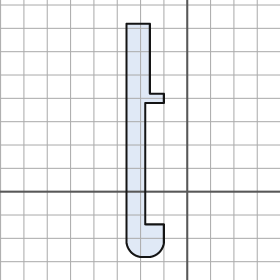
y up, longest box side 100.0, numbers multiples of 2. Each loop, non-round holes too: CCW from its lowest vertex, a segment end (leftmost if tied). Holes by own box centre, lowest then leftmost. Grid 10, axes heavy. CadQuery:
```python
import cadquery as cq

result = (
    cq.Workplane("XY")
    .moveTo(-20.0, -28.0)
    .lineTo(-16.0, -28.0)
    .threePointArc((-12.0, -26.0), (-10.0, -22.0))
    .lineTo(-10.0, -14.0)
    .lineTo(-18.0, -14.0)
    .lineTo(-18.0, 38.0)
    .lineTo(-10.0, 38.0)
    .lineTo(-10.0, 42.0)
    .lineTo(-16.0, 42.0)
    .lineTo(-16.0, 72.0)
    .lineTo(-26.0, 72.0)
    .lineTo(-26.0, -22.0)
    .threePointArc((-24.0, -26.0), (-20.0, -28.0))
    .close()
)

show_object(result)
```